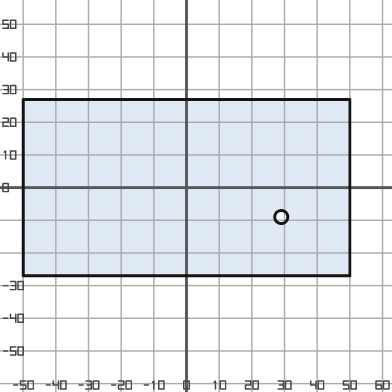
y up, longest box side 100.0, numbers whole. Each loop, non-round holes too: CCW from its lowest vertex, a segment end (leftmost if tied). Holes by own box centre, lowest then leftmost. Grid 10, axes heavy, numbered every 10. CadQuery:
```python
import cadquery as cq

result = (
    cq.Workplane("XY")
    .moveTo(-50.0, -27.0)
    .lineTo(50.0, -27.0)
    .lineTo(50.0, 27.0)
    .lineTo(-50.0, 27.0)
    .close()
    .moveTo(29.0, -9.0)
    .circle(2.0)
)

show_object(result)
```